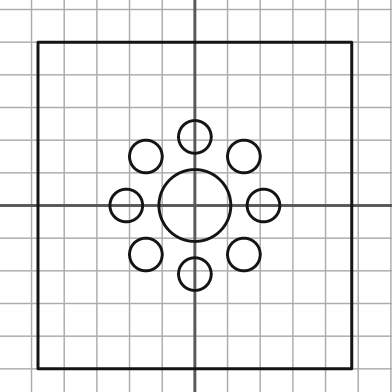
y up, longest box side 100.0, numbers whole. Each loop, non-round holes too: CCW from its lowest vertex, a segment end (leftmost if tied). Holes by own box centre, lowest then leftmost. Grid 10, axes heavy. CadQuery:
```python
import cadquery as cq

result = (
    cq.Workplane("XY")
    .moveTo(-48.0, -50.0)
    .lineTo(48.0, -50.0)
    .lineTo(48.0, 50.0)
    .lineTo(-48.0, 50.0)
    .close()
    .moveTo(0.0, -21.0)
    .circle(5.0)
    .moveTo(-15.0, -15.0)
    .circle(5.0)
    .moveTo(15.0, -15.0)
    .circle(5.0)
    .moveTo(-21.0, 0.0)
    .circle(5.0)
    .moveTo(0.0, 0.0)
    .circle(11.0)
    .moveTo(21.0, 0.0)
    .circle(5.0)
    .moveTo(-15.0, 15.0)
    .circle(5.0)
    .moveTo(15.0, 15.0)
    .circle(5.0)
    .moveTo(0.0, 21.0)
    .circle(5.0)
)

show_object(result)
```